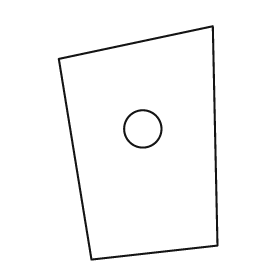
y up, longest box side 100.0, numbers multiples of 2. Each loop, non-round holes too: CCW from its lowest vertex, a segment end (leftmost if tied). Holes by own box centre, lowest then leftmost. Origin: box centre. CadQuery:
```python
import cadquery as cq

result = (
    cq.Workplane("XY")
    .moveTo(-20.0, -50.0)
    .lineTo(34.0, -44.0)
    .lineTo(32.0, 50.0)
    .lineTo(-34.0, 36.0)
    .close()
    .moveTo(2.0, 6.0)
    .circle(8.0)
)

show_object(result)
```